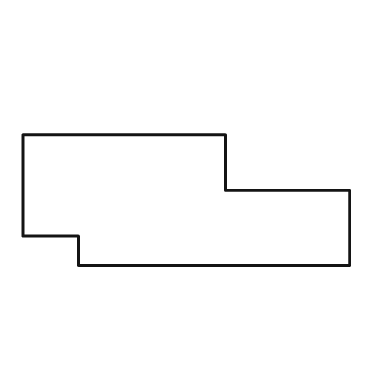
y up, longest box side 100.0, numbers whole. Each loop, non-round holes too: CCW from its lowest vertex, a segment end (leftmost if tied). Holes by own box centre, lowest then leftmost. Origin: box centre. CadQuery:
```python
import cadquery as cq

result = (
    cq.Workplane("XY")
    .moveTo(-33.0, -20.0)
    .lineTo(50.0, -20.0)
    .lineTo(50.0, 3.0)
    .lineTo(12.0, 3.0)
    .lineTo(12.0, 20.0)
    .lineTo(-50.0, 20.0)
    .lineTo(-50.0, -11.0)
    .lineTo(-33.0, -11.0)
    .close()
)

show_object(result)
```